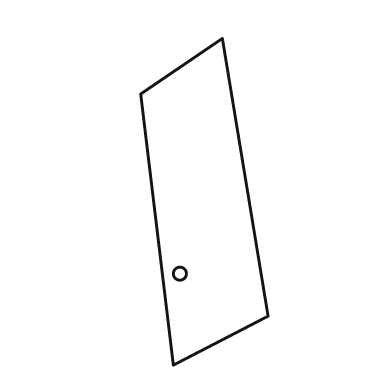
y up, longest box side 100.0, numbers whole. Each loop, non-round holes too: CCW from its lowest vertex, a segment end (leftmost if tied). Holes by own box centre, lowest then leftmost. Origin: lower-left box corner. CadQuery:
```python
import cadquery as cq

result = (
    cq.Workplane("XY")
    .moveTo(10.0, 0.0)
    .lineTo(39.0, 15.0)
    .lineTo(25.0, 100.0)
    .lineTo(0.0, 83.0)
    .close()
    .moveTo(12.0, 28.0)
    .circle(2.0)
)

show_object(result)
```